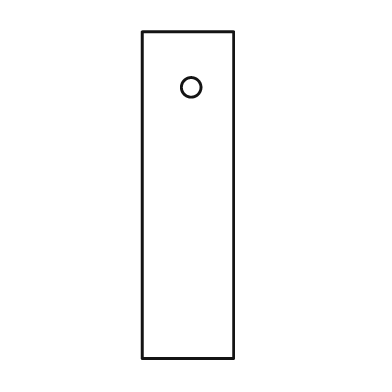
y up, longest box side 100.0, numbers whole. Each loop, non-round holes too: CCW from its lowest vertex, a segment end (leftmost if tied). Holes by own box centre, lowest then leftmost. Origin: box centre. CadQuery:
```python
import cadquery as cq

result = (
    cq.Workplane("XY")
    .moveTo(-14.0, -50.0)
    .lineTo(14.0, -50.0)
    .lineTo(14.0, 50.0)
    .lineTo(-14.0, 50.0)
    .close()
    .moveTo(1.0, 33.0)
    .circle(3.0)
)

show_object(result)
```